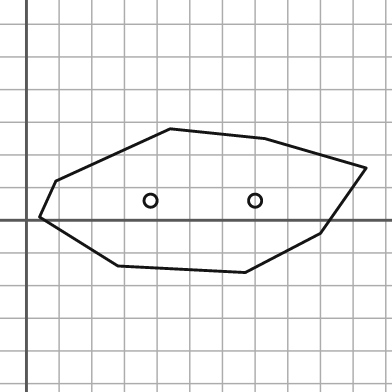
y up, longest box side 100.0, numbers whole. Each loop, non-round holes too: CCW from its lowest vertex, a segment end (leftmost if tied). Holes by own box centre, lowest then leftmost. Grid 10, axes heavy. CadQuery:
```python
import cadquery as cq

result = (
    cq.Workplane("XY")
    .moveTo(67.0, -16.0)
    .lineTo(90.0, -4.0)
    .lineTo(104.0, 16.0)
    .lineTo(73.0, 25.0)
    .lineTo(44.0, 28.0)
    .lineTo(9.0, 12.0)
    .lineTo(4.0, 1.0)
    .lineTo(28.0, -14.0)
    .close()
    .moveTo(38.0, 6.0)
    .circle(2.0)
    .moveTo(70.0, 6.0)
    .circle(2.0)
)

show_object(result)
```